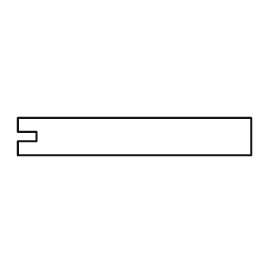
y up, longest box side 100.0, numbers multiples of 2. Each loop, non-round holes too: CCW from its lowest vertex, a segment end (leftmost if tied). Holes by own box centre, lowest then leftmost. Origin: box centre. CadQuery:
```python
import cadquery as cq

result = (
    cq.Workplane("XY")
    .moveTo(-50.0, -8.0)
    .lineTo(50.0, -8.0)
    .lineTo(50.0, 8.0)
    .lineTo(-50.0, 8.0)
    .lineTo(-50.0, 2.0)
    .lineTo(-42.0, 2.0)
    .lineTo(-42.0, -2.0)
    .lineTo(-50.0, -2.0)
    .close()
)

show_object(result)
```